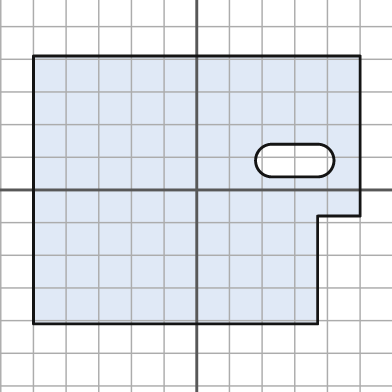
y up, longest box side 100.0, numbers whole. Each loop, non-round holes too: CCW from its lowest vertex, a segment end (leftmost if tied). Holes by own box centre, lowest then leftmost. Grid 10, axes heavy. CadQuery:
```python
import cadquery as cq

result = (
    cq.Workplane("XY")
    .moveTo(-50.0, -41.0)
    .lineTo(37.0, -41.0)
    .lineTo(37.0, -8.0)
    .lineTo(50.0, -8.0)
    .lineTo(50.0, 41.0)
    .lineTo(-50.0, 41.0)
    .close()
    .moveTo(23.0, 4.0)
    .lineTo(37.0, 4.0)
    .threePointArc((42.0, 9.0), (37.0, 14.0))
    .lineTo(23.0, 14.0)
    .threePointArc((18.0, 9.0), (23.0, 4.0))
    .close()
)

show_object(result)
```